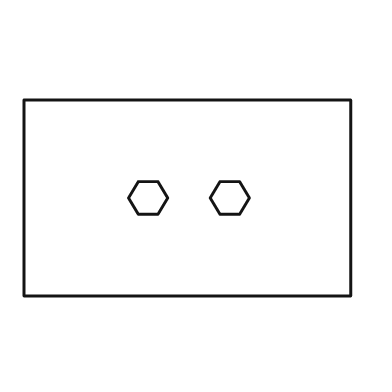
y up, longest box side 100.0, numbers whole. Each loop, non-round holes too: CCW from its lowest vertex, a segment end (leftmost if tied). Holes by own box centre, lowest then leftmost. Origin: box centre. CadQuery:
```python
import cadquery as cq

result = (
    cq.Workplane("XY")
    .moveTo(-50.0, -30.0)
    .lineTo(50.0, -30.0)
    .lineTo(50.0, 30.0)
    .lineTo(-50.0, 30.0)
    .close()
    .moveTo(-15.0, -5.0)
    .lineTo(-9.0, -5.0)
    .lineTo(-6.0, 0.0)
    .lineTo(-9.0, 5.0)
    .lineTo(-15.0, 5.0)
    .lineTo(-18.0, 0.0)
    .close()
    .moveTo(10.0, -5.0)
    .lineTo(16.0, -5.0)
    .lineTo(19.0, 0.0)
    .lineTo(16.0, 5.0)
    .lineTo(10.0, 5.0)
    .lineTo(7.0, 0.0)
    .close()
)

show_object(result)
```